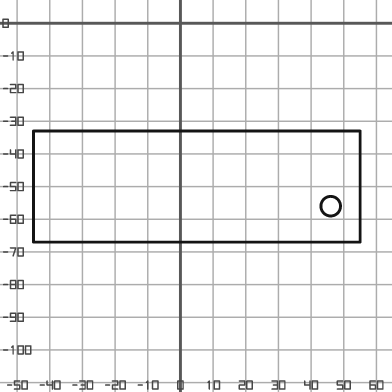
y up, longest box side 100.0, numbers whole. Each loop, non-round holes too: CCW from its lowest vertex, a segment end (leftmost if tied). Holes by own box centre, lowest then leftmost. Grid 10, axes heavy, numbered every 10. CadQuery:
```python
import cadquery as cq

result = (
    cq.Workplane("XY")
    .moveTo(-45.0, -67.0)
    .lineTo(55.0, -67.0)
    .lineTo(55.0, -33.0)
    .lineTo(-45.0, -33.0)
    .close()
    .moveTo(46.0, -56.0)
    .circle(3.0)
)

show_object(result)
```